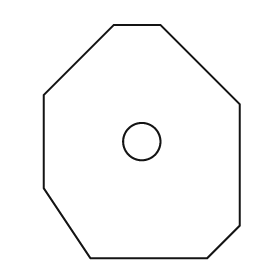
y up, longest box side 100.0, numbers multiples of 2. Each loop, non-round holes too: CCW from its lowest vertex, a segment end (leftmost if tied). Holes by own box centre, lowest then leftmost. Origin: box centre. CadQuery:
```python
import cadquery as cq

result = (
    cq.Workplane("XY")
    .moveTo(-22.0, -50.0)
    .lineTo(28.0, -50.0)
    .lineTo(42.0, -36.0)
    .lineTo(42.0, 16.0)
    .lineTo(8.0, 50.0)
    .lineTo(-12.0, 50.0)
    .lineTo(-42.0, 20.0)
    .lineTo(-42.0, -20.0)
    .close()
    .moveTo(0.0, 0.0)
    .circle(8.0)
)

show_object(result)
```